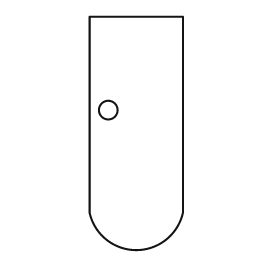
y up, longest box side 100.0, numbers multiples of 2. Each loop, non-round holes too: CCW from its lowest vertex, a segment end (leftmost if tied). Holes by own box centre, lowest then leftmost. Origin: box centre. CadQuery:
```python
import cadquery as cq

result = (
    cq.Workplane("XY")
    .moveTo(-20.0, -34.0)
    .threePointArc((0.0, -50.0), (20.0, -34.0))
    .lineTo(20.0, 50.0)
    .lineTo(-20.0, 50.0)
    .close()
    .moveTo(-12.0, 10.0)
    .circle(4.0)
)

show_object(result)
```